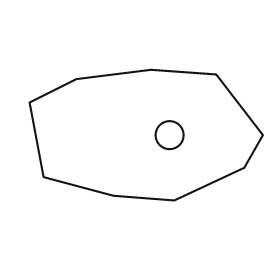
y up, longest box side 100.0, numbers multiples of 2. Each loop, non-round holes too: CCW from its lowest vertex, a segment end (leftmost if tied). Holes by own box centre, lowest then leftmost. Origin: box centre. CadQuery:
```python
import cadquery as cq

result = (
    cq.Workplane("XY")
    .moveTo(12.0, -28.0)
    .lineTo(42.0, -14.0)
    .lineTo(50.0, 0.0)
    .lineTo(30.0, 26.0)
    .lineTo(2.0, 28.0)
    .lineTo(-30.0, 24.0)
    .lineTo(-50.0, 14.0)
    .lineTo(-44.0, -18.0)
    .lineTo(-14.0, -26.0)
    .close()
    .moveTo(10.0, 0.0)
    .circle(6.0)
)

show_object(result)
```